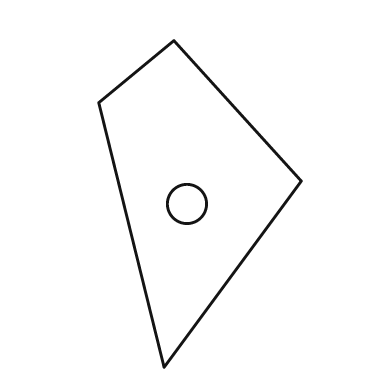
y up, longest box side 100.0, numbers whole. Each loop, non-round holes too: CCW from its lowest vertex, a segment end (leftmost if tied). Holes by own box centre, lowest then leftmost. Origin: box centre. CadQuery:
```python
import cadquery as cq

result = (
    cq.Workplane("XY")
    .moveTo(-11.0, -50.0)
    .lineTo(31.0, 7.0)
    .lineTo(-8.0, 50.0)
    .lineTo(-31.0, 31.0)
    .close()
    .moveTo(-4.0, 0.0)
    .circle(6.0)
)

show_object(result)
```